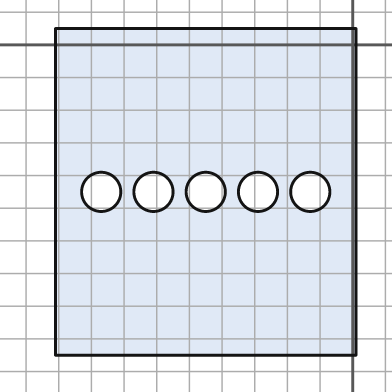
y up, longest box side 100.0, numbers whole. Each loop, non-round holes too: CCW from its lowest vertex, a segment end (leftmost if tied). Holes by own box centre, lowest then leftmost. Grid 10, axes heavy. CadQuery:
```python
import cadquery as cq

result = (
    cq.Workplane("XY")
    .moveTo(-91.0, -95.0)
    .lineTo(1.0, -95.0)
    .lineTo(1.0, 5.0)
    .lineTo(-91.0, 5.0)
    .close()
    .moveTo(-77.0, -45.0)
    .circle(6.0)
    .moveTo(-61.0, -45.0)
    .circle(6.0)
    .moveTo(-45.0, -45.0)
    .circle(6.0)
    .moveTo(-29.0, -45.0)
    .circle(6.0)
    .moveTo(-13.0, -45.0)
    .circle(6.0)
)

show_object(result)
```